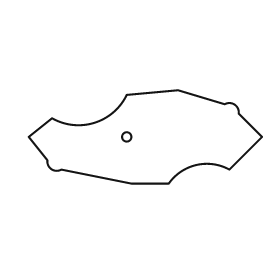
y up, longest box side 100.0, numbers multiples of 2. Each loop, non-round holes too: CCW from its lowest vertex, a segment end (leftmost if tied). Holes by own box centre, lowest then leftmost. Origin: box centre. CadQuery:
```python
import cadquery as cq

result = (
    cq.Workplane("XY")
    .moveTo(-6.0, -20.0)
    .lineTo(10.0, -20.0)
    .threePointArc((22.0, -12.0), (36.0, -14.0))
    .lineTo(50.0, 0.0)
    .lineTo(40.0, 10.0)
    .threePointArc((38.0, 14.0), (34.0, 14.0))
    .lineTo(14.0, 20.0)
    .lineTo(-8.0, 18.0)
    .threePointArc((-22.0, 6.0), (-40.0, 8.0))
    .lineTo(-50.0, 0.0)
    .lineTo(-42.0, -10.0)
    .threePointArc((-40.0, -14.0), (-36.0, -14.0))
    .close()
    .moveTo(-8.0, 0.0)
    .circle(2.0)
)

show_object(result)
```